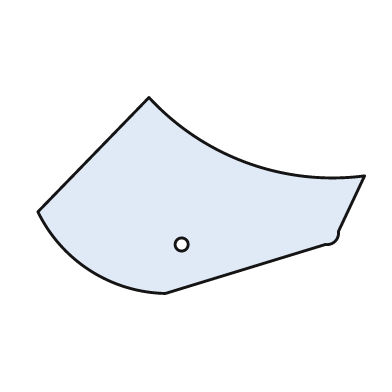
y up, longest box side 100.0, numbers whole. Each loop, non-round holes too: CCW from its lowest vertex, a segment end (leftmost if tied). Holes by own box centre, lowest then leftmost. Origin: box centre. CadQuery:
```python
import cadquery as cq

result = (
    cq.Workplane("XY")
    .moveTo(-11.0, -30.0)
    .lineTo(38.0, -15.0)
    .threePointArc((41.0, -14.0), (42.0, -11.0))
    .lineTo(50.0, 6.0)
    .threePointArc((14.0, 10.0), (-16.0, 30.0))
    .lineTo(-50.0, -5.0)
    .threePointArc((-34.0, -23.0), (-11.0, -30.0))
    .close()
    .moveTo(-6.0, -15.0)
    .circle(2.0)
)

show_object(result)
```